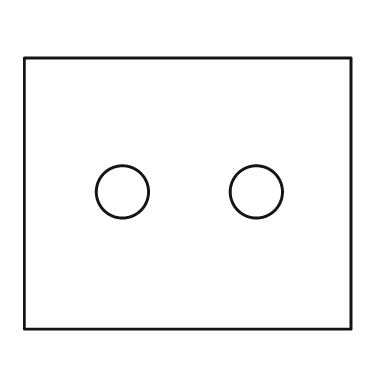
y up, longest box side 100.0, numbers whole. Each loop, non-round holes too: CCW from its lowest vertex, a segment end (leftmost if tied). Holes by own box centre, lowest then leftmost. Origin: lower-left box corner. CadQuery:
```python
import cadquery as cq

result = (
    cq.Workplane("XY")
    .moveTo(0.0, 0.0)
    .lineTo(100.0, 0.0)
    .lineTo(100.0, 83.0)
    .lineTo(0.0, 83.0)
    .close()
    .moveTo(30.0, 42.0)
    .circle(8.0)
    .moveTo(71.0, 42.0)
    .circle(8.0)
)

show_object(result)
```